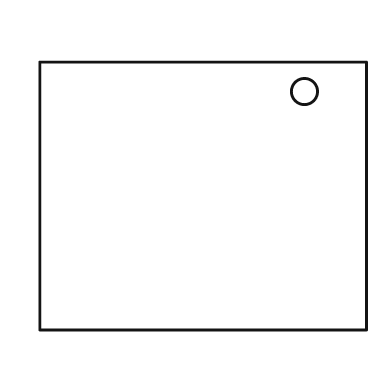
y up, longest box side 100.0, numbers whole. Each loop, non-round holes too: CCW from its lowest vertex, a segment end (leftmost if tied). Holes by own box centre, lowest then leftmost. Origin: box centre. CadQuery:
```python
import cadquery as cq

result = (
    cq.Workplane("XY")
    .moveTo(-50.0, -41.0)
    .lineTo(50.0, -41.0)
    .lineTo(50.0, 41.0)
    .lineTo(-50.0, 41.0)
    .close()
    .moveTo(31.0, 32.0)
    .circle(4.0)
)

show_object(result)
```